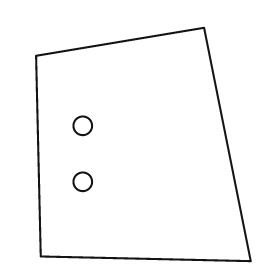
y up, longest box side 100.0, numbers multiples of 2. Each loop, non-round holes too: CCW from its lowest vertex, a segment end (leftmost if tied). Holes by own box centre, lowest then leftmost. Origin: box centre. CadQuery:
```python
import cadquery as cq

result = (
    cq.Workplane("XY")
    .moveTo(46.0, -50.0)
    .lineTo(26.0, 50.0)
    .lineTo(-46.0, 38.0)
    .lineTo(-44.0, -48.0)
    .close()
    .moveTo(-26.0, -16.0)
    .circle(4.0)
    .moveTo(-26.0, 8.0)
    .circle(4.0)
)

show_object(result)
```